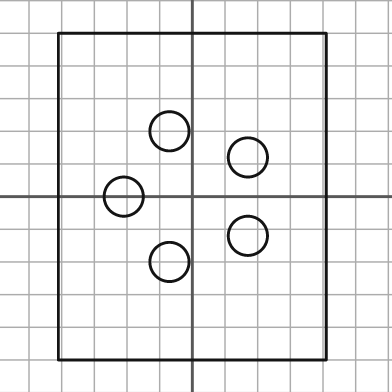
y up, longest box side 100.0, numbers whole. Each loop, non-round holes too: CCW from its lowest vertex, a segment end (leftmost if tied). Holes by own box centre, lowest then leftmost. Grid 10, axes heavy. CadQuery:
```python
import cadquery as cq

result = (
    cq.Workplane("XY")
    .moveTo(-41.0, -50.0)
    .lineTo(41.0, -50.0)
    .lineTo(41.0, 50.0)
    .lineTo(-41.0, 50.0)
    .close()
    .moveTo(-7.0, -20.0)
    .circle(6.0)
    .moveTo(17.0, -12.0)
    .circle(6.0)
    .moveTo(-21.0, 0.0)
    .circle(6.0)
    .moveTo(17.0, 12.0)
    .circle(6.0)
    .moveTo(-7.0, 20.0)
    .circle(6.0)
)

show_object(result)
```